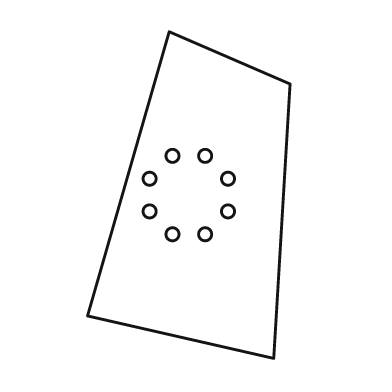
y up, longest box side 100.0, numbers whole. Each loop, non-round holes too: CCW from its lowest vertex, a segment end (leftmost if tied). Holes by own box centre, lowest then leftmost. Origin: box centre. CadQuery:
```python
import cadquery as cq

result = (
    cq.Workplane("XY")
    .moveTo(26.0, -50.0)
    .lineTo(31.0, 34.0)
    .lineTo(-6.0, 50.0)
    .lineTo(-31.0, -37.0)
    .close()
    .moveTo(-5.0, -12.0)
    .circle(2.0)
    .moveTo(5.0, -12.0)
    .circle(2.0)
    .moveTo(-12.0, -5.0)
    .circle(2.0)
    .moveTo(12.0, -5.0)
    .circle(2.0)
    .moveTo(-12.0, 5.0)
    .circle(2.0)
    .moveTo(12.0, 5.0)
    .circle(2.0)
    .moveTo(-5.0, 12.0)
    .circle(2.0)
    .moveTo(5.0, 12.0)
    .circle(2.0)
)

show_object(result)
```